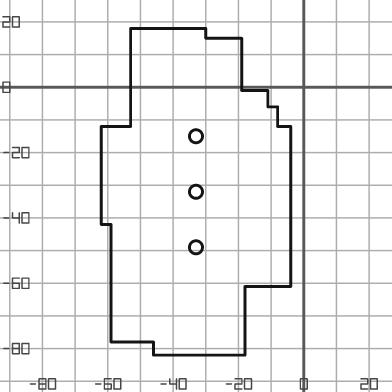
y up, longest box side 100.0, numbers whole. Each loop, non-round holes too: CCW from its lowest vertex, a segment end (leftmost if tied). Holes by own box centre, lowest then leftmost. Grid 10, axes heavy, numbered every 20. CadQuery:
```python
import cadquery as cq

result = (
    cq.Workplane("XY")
    .moveTo(-46.0, -82.0)
    .lineTo(-18.0, -82.0)
    .lineTo(-18.0, -61.0)
    .lineTo(-4.0, -61.0)
    .lineTo(-4.0, -12.0)
    .lineTo(-8.0, -12.0)
    .lineTo(-8.0, -6.0)
    .lineTo(-11.0, -6.0)
    .lineTo(-11.0, -1.0)
    .lineTo(-19.0, -1.0)
    .lineTo(-19.0, 15.0)
    .lineTo(-30.0, 15.0)
    .lineTo(-30.0, 18.0)
    .lineTo(-53.0, 18.0)
    .lineTo(-53.0, -12.0)
    .lineTo(-62.0, -12.0)
    .lineTo(-62.0, -42.0)
    .lineTo(-59.0, -42.0)
    .lineTo(-59.0, -78.0)
    .lineTo(-46.0, -78.0)
    .close()
    .moveTo(-33.0, -49.0)
    .circle(2.0)
    .moveTo(-33.0, -32.0)
    .circle(2.0)
    .moveTo(-33.0, -15.0)
    .circle(2.0)
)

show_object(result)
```